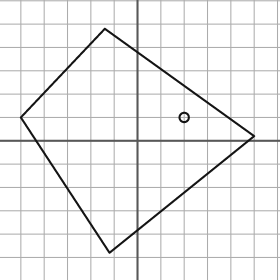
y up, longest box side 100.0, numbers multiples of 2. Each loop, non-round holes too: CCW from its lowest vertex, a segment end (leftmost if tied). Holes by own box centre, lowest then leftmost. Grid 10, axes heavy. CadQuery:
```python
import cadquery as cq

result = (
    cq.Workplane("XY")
    .moveTo(-12.0, -48.0)
    .lineTo(50.0, 2.0)
    .lineTo(-14.0, 48.0)
    .lineTo(-50.0, 10.0)
    .close()
    .moveTo(20.0, 10.0)
    .circle(2.0)
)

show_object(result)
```